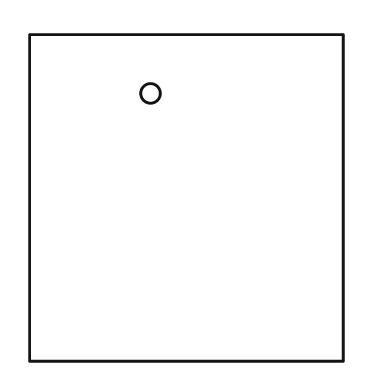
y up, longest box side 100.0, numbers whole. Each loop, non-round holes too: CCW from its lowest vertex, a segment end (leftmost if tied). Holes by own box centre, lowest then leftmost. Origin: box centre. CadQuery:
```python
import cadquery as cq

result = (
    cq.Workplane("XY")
    .moveTo(-48.0, -50.0)
    .lineTo(48.0, -50.0)
    .lineTo(48.0, 50.0)
    .lineTo(-48.0, 50.0)
    .close()
    .moveTo(-11.0, 32.0)
    .circle(3.0)
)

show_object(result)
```